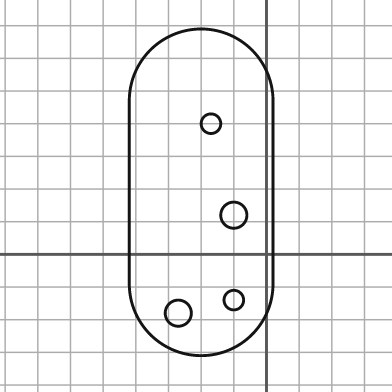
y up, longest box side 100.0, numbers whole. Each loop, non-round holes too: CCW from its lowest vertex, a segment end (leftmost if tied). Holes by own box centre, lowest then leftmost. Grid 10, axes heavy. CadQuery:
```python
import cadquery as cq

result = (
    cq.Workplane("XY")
    .moveTo(-42.0, -9.0)
    .threePointArc((-20.0, -31.0), (2.0, -9.0))
    .lineTo(2.0, 47.0)
    .threePointArc((-20.0, 69.0), (-42.0, 47.0))
    .close()
    .moveTo(-27.0, -18.0)
    .circle(4.0)
    .moveTo(-10.0, -14.0)
    .circle(3.0)
    .moveTo(-10.0, 12.0)
    .circle(4.0)
    .moveTo(-17.0, 40.0)
    .circle(3.0)
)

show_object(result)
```